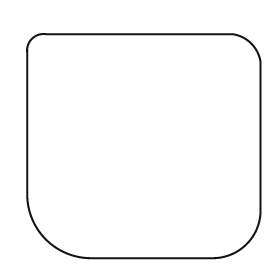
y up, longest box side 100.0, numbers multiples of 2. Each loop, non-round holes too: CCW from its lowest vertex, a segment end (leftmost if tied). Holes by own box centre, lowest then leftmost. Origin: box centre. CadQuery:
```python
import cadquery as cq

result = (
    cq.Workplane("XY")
    .moveTo(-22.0, -48.0)
    .lineTo(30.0, -48.0)
    .threePointArc((44.0, -42.0), (50.0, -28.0))
    .lineTo(50.0, 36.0)
    .threePointArc((46.0, 44.0), (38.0, 48.0))
    .lineTo(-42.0, 48.0)
    .threePointArc((-48.0, 46.0), (-50.0, 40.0))
    .lineTo(-50.0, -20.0)
    .threePointArc((-42.0, -40.0), (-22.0, -48.0))
    .close()
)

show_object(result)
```